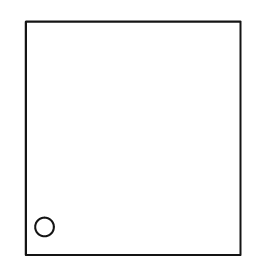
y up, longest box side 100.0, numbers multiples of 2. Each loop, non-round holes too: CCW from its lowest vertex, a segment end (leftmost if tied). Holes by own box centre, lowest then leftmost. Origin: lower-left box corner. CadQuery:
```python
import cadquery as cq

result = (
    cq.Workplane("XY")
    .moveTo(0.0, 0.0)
    .lineTo(92.0, 0.0)
    .lineTo(92.0, 100.0)
    .lineTo(0.0, 100.0)
    .close()
    .moveTo(8.0, 12.0)
    .circle(4.0)
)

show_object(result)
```